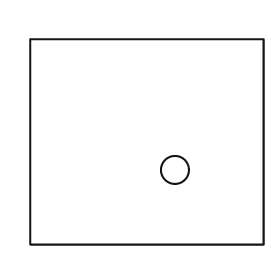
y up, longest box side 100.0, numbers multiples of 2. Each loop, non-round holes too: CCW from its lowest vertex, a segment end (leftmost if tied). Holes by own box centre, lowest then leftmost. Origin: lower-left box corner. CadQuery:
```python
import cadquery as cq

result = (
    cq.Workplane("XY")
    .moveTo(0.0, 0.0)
    .lineTo(100.0, 0.0)
    .lineTo(100.0, 88.0)
    .lineTo(0.0, 88.0)
    .close()
    .moveTo(62.0, 32.0)
    .circle(6.0)
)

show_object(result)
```